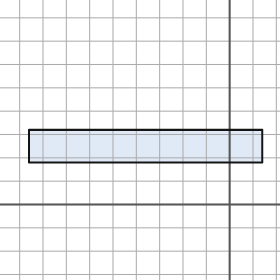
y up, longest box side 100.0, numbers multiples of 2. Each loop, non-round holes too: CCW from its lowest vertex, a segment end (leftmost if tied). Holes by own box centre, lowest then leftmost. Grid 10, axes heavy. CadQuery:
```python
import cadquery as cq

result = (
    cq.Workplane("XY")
    .moveTo(-86.0, 18.0)
    .lineTo(14.0, 18.0)
    .lineTo(14.0, 32.0)
    .lineTo(-86.0, 32.0)
    .close()
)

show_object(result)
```